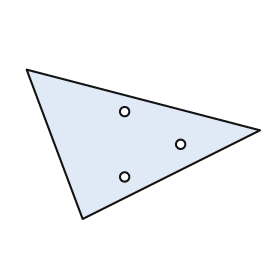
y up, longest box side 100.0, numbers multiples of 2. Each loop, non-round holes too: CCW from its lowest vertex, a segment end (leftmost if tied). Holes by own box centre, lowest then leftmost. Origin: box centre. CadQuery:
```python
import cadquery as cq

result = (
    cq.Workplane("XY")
    .moveTo(-26.0, -32.0)
    .lineTo(50.0, 6.0)
    .lineTo(-50.0, 32.0)
    .close()
    .moveTo(-8.0, -14.0)
    .circle(2.0)
    .moveTo(16.0, 0.0)
    .circle(2.0)
    .moveTo(-8.0, 14.0)
    .circle(2.0)
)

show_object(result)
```